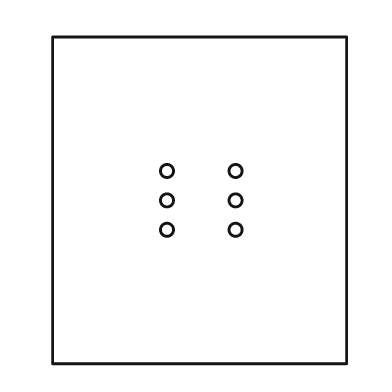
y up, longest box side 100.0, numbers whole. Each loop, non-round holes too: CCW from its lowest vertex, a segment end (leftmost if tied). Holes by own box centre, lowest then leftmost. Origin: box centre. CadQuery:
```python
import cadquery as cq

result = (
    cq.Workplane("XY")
    .moveTo(-45.0, -50.0)
    .lineTo(45.0, -50.0)
    .lineTo(45.0, 50.0)
    .lineTo(-45.0, 50.0)
    .close()
    .moveTo(-10.0, -9.0)
    .circle(2.0)
    .moveTo(11.0, -9.0)
    .circle(2.0)
    .moveTo(-10.0, 0.0)
    .circle(2.0)
    .moveTo(11.0, 0.0)
    .circle(2.0)
    .moveTo(-10.0, 9.0)
    .circle(2.0)
    .moveTo(11.0, 9.0)
    .circle(2.0)
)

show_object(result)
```